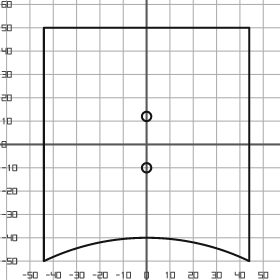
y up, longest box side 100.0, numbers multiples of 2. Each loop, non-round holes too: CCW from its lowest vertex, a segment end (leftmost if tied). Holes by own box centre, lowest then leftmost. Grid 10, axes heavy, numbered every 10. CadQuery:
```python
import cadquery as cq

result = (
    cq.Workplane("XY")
    .moveTo(-44.0, -50.0)
    .threePointArc((0.0, -40.0), (44.0, -50.0))
    .lineTo(44.0, 50.0)
    .lineTo(-44.0, 50.0)
    .close()
    .moveTo(0.0, -10.0)
    .circle(2.0)
    .moveTo(0.0, 12.0)
    .circle(2.0)
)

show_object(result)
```